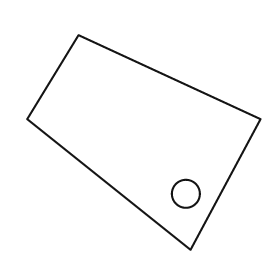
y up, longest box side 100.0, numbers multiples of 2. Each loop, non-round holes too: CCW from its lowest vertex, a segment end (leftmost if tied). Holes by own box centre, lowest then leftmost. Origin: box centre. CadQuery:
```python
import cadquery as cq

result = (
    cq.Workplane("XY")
    .moveTo(20.0, -46.0)
    .lineTo(50.0, 10.0)
    .lineTo(-28.0, 46.0)
    .lineTo(-50.0, 10.0)
    .close()
    .moveTo(18.0, -22.0)
    .circle(6.0)
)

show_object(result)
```